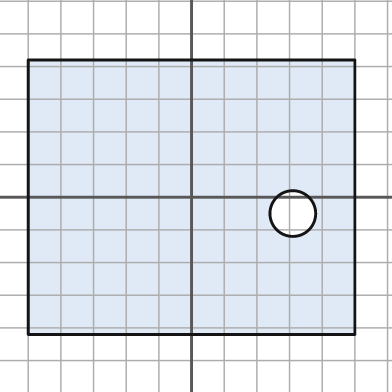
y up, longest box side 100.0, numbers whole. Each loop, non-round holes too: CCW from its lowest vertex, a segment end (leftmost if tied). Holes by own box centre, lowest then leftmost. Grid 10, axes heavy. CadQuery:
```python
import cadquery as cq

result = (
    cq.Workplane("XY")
    .moveTo(-50.0, -42.0)
    .lineTo(50.0, -42.0)
    .lineTo(50.0, 42.0)
    .lineTo(-50.0, 42.0)
    .close()
    .moveTo(31.0, -5.0)
    .circle(7.0)
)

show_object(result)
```